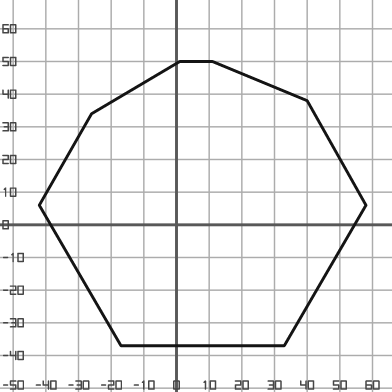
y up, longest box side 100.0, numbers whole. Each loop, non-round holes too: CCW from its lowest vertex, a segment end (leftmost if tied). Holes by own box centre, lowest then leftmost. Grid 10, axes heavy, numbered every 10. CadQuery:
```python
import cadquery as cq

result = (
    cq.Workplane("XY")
    .moveTo(-17.0, -37.0)
    .lineTo(33.0, -37.0)
    .lineTo(58.0, 6.0)
    .lineTo(40.0, 38.0)
    .lineTo(11.0, 50.0)
    .lineTo(1.0, 50.0)
    .lineTo(-26.0, 34.0)
    .lineTo(-42.0, 6.0)
    .close()
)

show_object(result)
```